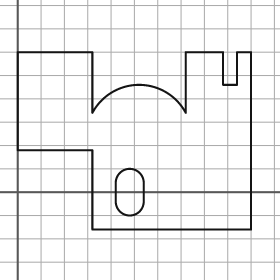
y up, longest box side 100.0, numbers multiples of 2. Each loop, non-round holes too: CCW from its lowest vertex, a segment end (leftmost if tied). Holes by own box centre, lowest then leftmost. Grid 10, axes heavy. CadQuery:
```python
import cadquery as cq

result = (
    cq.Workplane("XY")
    .moveTo(32.0, -16.0)
    .lineTo(100.0, -16.0)
    .lineTo(100.0, 60.0)
    .lineTo(94.0, 60.0)
    .lineTo(94.0, 46.0)
    .lineTo(88.0, 46.0)
    .lineTo(88.0, 60.0)
    .lineTo(72.0, 60.0)
    .lineTo(72.0, 34.0)
    .threePointArc((52.0, 46.0), (32.0, 34.0))
    .lineTo(32.0, 60.0)
    .lineTo(0.0, 60.0)
    .lineTo(0.0, 18.0)
    .lineTo(32.0, 18.0)
    .close()
    .moveTo(42.0, -4.0)
    .threePointArc((48.0, -10.0), (54.0, -4.0))
    .lineTo(54.0, 4.0)
    .threePointArc((48.0, 10.0), (42.0, 4.0))
    .close()
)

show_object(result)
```